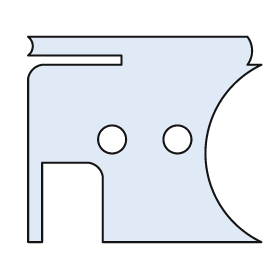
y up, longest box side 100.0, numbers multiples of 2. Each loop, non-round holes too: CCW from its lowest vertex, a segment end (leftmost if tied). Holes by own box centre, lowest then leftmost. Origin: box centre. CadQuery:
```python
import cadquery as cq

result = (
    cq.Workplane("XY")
    .moveTo(-50.0, -44.0)
    .lineTo(-44.0, -44.0)
    .lineTo(-44.0, -10.0)
    .lineTo(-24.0, -10.0)
    .threePointArc((-20.0, -12.0), (-18.0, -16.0))
    .lineTo(-18.0, -44.0)
    .lineTo(50.0, -44.0)
    .threePointArc((26.0, -6.0), (50.0, 32.0))
    .lineTo(44.0, 32.0)
    .threePointArc((46.0, 38.0), (44.0, 44.0))
    .lineTo(-50.0, 44.0)
    .threePointArc((-48.0, 40.0), (-50.0, 36.0))
    .lineTo(-10.0, 36.0)
    .lineTo(-10.0, 32.0)
    .lineTo(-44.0, 32.0)
    .threePointArc((-48.0, 30.0), (-50.0, 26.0))
    .close()
    .moveTo(-14.0, 0.0)
    .circle(6.0)
    .moveTo(14.0, 0.0)
    .circle(6.0)
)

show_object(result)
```